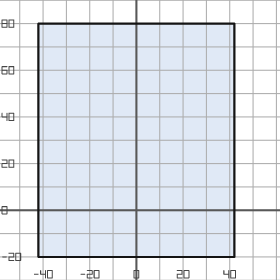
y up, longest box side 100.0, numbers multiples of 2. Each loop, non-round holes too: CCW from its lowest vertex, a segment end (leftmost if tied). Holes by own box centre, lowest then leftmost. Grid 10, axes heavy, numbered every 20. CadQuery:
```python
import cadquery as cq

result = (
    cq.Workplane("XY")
    .moveTo(-42.0, -20.0)
    .lineTo(42.0, -20.0)
    .lineTo(42.0, 80.0)
    .lineTo(-42.0, 80.0)
    .close()
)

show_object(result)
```